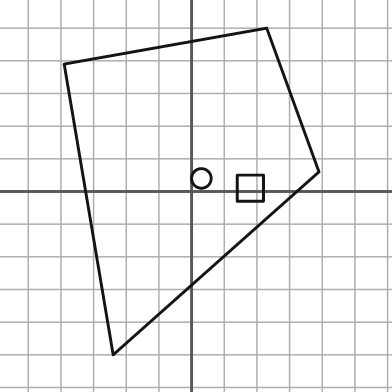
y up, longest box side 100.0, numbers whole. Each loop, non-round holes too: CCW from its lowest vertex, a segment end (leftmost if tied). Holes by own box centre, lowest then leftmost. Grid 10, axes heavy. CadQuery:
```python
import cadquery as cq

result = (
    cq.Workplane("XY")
    .moveTo(-24.0, -50.0)
    .lineTo(39.0, 6.0)
    .lineTo(23.0, 50.0)
    .lineTo(-39.0, 39.0)
    .close()
    .moveTo(14.0, -3.0)
    .lineTo(22.0, -3.0)
    .lineTo(22.0, 5.0)
    .lineTo(14.0, 5.0)
    .close()
    .moveTo(3.0, 4.0)
    .circle(3.0)
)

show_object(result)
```